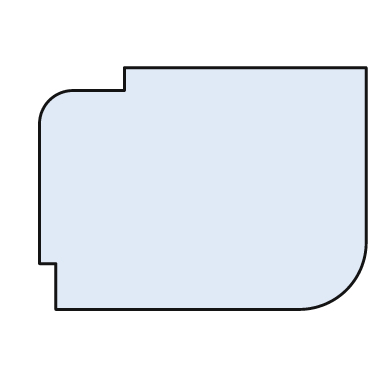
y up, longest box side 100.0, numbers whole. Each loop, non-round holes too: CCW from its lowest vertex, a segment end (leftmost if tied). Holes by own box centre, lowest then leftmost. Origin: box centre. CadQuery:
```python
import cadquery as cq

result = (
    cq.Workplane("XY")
    .moveTo(-45.0, -37.0)
    .lineTo(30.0, -37.0)
    .threePointArc((44.0, -31.0), (50.0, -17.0))
    .lineTo(50.0, 37.0)
    .lineTo(-24.0, 37.0)
    .lineTo(-24.0, 30.0)
    .lineTo(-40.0, 30.0)
    .threePointArc((-47.0, 27.0), (-50.0, 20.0))
    .lineTo(-50.0, -23.0)
    .lineTo(-45.0, -23.0)
    .close()
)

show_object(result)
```